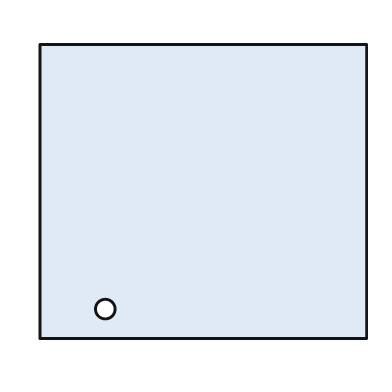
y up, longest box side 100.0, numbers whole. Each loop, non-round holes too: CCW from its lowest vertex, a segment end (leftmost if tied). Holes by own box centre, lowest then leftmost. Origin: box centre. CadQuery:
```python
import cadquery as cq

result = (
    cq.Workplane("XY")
    .moveTo(-50.0, -45.0)
    .lineTo(50.0, -45.0)
    .lineTo(50.0, 45.0)
    .lineTo(-50.0, 45.0)
    .close()
    .moveTo(-30.0, -36.0)
    .circle(3.0)
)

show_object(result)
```